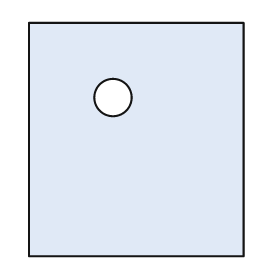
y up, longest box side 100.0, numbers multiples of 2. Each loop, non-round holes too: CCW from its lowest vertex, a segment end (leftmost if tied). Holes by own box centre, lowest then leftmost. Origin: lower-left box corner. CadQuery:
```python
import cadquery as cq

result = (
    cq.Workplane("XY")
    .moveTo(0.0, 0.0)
    .lineTo(92.0, 0.0)
    .lineTo(92.0, 100.0)
    .lineTo(0.0, 100.0)
    .close()
    .moveTo(36.0, 68.0)
    .circle(8.0)
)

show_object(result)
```